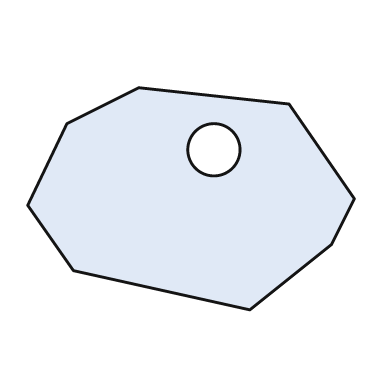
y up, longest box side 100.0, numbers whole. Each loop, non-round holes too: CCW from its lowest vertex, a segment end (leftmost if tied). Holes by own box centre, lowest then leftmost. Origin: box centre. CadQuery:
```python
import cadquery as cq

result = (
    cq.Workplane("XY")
    .moveTo(18.0, -34.0)
    .lineTo(43.0, -14.0)
    .lineTo(50.0, 0.0)
    .lineTo(30.0, 29.0)
    .lineTo(-16.0, 34.0)
    .lineTo(-38.0, 23.0)
    .lineTo(-50.0, -2.0)
    .lineTo(-36.0, -22.0)
    .close()
    .moveTo(7.0, 15.0)
    .circle(8.0)
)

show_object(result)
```